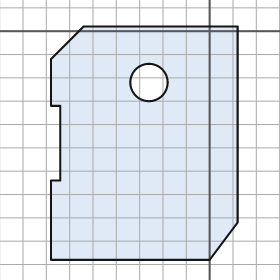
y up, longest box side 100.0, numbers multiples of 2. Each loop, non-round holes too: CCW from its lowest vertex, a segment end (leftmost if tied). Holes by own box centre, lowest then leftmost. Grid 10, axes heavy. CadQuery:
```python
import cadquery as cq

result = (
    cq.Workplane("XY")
    .moveTo(-68.0, -98.0)
    .lineTo(0.0, -98.0)
    .lineTo(12.0, -82.0)
    .lineTo(12.0, 2.0)
    .lineTo(-54.0, 2.0)
    .lineTo(-68.0, -12.0)
    .lineTo(-68.0, -32.0)
    .lineTo(-64.0, -32.0)
    .lineTo(-64.0, -64.0)
    .lineTo(-68.0, -64.0)
    .close()
    .moveTo(-26.0, -22.0)
    .circle(8.0)
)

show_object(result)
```